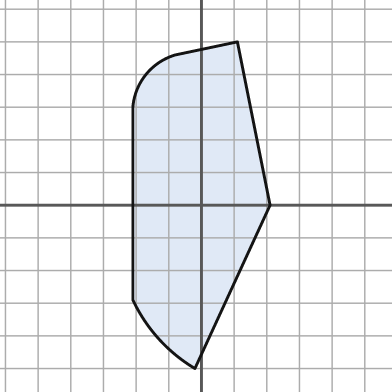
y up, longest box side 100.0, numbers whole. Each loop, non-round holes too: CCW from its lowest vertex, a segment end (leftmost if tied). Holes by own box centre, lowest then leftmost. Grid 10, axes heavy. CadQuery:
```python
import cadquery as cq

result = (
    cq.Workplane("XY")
    .moveTo(-2.0, -50.0)
    .lineTo(21.0, 0.0)
    .lineTo(11.0, 50.0)
    .lineTo(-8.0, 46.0)
    .threePointArc((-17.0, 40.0), (-21.0, 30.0))
    .lineTo(-21.0, -29.0)
    .threePointArc((-13.0, -41.0), (-2.0, -50.0))
    .close()
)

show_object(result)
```